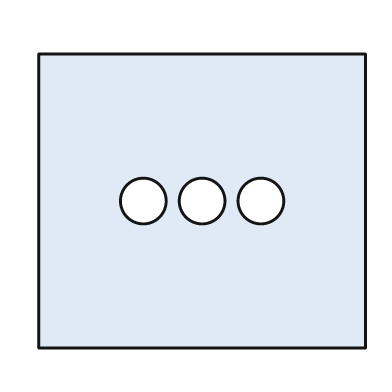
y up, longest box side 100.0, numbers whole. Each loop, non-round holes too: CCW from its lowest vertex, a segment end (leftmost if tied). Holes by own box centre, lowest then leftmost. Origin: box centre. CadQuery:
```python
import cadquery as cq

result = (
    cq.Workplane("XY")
    .moveTo(-50.0, -45.0)
    .lineTo(50.0, -45.0)
    .lineTo(50.0, 45.0)
    .lineTo(-50.0, 45.0)
    .close()
    .moveTo(-18.0, 0.0)
    .circle(7.0)
    .moveTo(0.0, 0.0)
    .circle(7.0)
    .moveTo(18.0, 0.0)
    .circle(7.0)
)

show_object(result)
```